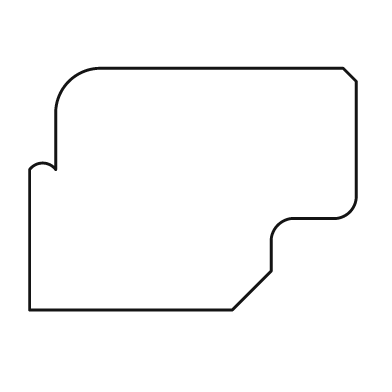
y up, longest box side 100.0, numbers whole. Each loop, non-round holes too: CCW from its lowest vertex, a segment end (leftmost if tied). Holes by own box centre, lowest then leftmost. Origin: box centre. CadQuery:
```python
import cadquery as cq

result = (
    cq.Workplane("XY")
    .moveTo(-50.0, -37.0)
    .lineTo(12.0, -37.0)
    .lineTo(24.0, -25.0)
    .lineTo(24.0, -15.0)
    .threePointArc((26.0, -11.0), (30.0, -9.0))
    .lineTo(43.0, -9.0)
    .threePointArc((48.0, -7.0), (50.0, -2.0))
    .lineTo(50.0, 33.0)
    .lineTo(46.0, 37.0)
    .lineTo(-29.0, 37.0)
    .threePointArc((-38.0, 33.0), (-42.0, 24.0))
    .lineTo(-42.0, 6.0)
    .threePointArc((-46.0, 8.0), (-50.0, 6.0))
    .close()
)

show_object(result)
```